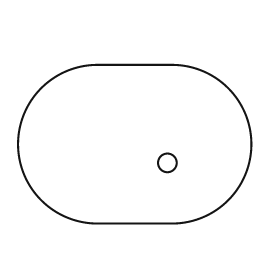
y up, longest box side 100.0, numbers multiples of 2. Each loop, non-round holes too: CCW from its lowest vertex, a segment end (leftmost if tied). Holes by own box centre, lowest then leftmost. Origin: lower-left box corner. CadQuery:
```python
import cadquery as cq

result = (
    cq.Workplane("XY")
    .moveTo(34.0, 0.0)
    .lineTo(66.0, 0.0)
    .threePointArc((100.0, 34.0), (66.0, 68.0))
    .lineTo(34.0, 68.0)
    .threePointArc((0.0, 34.0), (34.0, 0.0))
    .close()
    .moveTo(64.0, 26.0)
    .circle(4.0)
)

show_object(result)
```